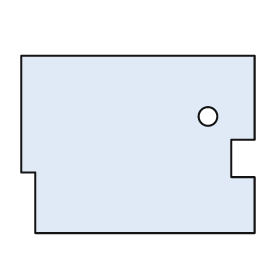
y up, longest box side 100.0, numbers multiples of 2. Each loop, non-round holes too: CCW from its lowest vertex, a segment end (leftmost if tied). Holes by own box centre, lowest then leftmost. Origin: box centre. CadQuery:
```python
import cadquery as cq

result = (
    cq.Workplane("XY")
    .moveTo(-44.0, -38.0)
    .lineTo(50.0, -38.0)
    .lineTo(50.0, -14.0)
    .lineTo(40.0, -14.0)
    .lineTo(40.0, 2.0)
    .lineTo(50.0, 2.0)
    .lineTo(50.0, 38.0)
    .lineTo(-50.0, 38.0)
    .lineTo(-50.0, -12.0)
    .lineTo(-44.0, -12.0)
    .close()
    .moveTo(30.0, 12.0)
    .circle(4.0)
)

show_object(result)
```